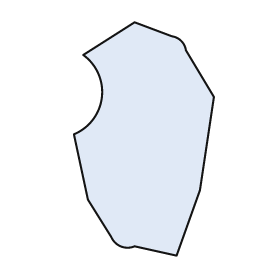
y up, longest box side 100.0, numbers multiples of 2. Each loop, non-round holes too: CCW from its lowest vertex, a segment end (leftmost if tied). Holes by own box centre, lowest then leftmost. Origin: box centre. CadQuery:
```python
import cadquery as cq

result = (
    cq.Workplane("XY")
    .moveTo(14.0, -50.0)
    .lineTo(24.0, -22.0)
    .lineTo(30.0, 18.0)
    .lineTo(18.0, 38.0)
    .threePointArc((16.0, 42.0), (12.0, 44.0))
    .lineTo(-4.0, 50.0)
    .lineTo(-26.0, 36.0)
    .threePointArc((-18.0, 18.0), (-30.0, 2.0))
    .lineTo(-24.0, -26.0)
    .lineTo(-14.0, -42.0)
    .threePointArc((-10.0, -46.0), (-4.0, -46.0))
    .close()
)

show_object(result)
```